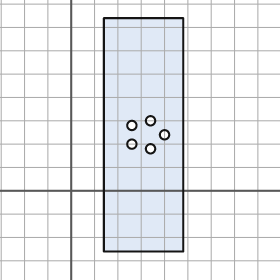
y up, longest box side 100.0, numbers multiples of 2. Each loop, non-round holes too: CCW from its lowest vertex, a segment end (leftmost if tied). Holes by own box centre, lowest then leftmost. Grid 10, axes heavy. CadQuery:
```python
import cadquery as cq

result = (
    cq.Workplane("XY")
    .moveTo(14.0, -26.0)
    .lineTo(48.0, -26.0)
    .lineTo(48.0, 74.0)
    .lineTo(14.0, 74.0)
    .close()
    .moveTo(34.0, 18.0)
    .circle(2.0)
    .moveTo(26.0, 20.0)
    .circle(2.0)
    .moveTo(40.0, 24.0)
    .circle(2.0)
    .moveTo(26.0, 28.0)
    .circle(2.0)
    .moveTo(34.0, 30.0)
    .circle(2.0)
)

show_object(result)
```